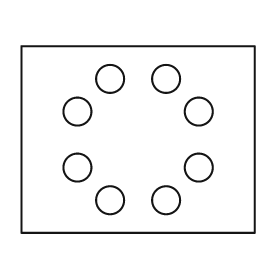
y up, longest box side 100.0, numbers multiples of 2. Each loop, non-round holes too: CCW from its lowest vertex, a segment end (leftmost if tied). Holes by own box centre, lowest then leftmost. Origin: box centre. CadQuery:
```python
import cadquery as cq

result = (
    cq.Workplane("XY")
    .moveTo(-50.0, -40.0)
    .lineTo(50.0, -40.0)
    .lineTo(50.0, 40.0)
    .lineTo(-50.0, 40.0)
    .close()
    .moveTo(-12.0, -26.0)
    .circle(6.0)
    .moveTo(12.0, -26.0)
    .circle(6.0)
    .moveTo(-26.0, -12.0)
    .circle(6.0)
    .moveTo(26.0, -12.0)
    .circle(6.0)
    .moveTo(-26.0, 12.0)
    .circle(6.0)
    .moveTo(26.0, 12.0)
    .circle(6.0)
    .moveTo(-12.0, 26.0)
    .circle(6.0)
    .moveTo(12.0, 26.0)
    .circle(6.0)
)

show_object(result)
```